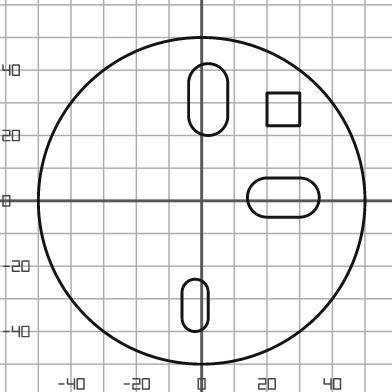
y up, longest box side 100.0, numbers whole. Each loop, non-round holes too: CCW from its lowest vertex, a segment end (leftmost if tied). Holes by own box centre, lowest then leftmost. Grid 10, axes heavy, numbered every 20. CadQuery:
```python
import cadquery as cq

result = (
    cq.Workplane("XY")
    .moveTo(0.0, 0.0)
    .circle(50.0)
    .moveTo(-6.0, -36.0)
    .threePointArc((-2.0, -40.0), (2.0, -36.0))
    .lineTo(2.0, -28.0)
    .threePointArc((-2.0, -24.0), (-6.0, -28.0))
    .close()
    .moveTo(20.0, -5.0)
    .lineTo(30.0, -5.0)
    .threePointArc((36.0, 1.0), (30.0, 7.0))
    .lineTo(20.0, 7.0)
    .threePointArc((14.0, 1.0), (20.0, -5.0))
    .close()
    .moveTo(20.0, 23.0)
    .lineTo(30.0, 23.0)
    .lineTo(30.0, 33.0)
    .lineTo(20.0, 33.0)
    .close()
    .moveTo(-4.0, 26.0)
    .threePointArc((2.0, 20.0), (8.0, 26.0))
    .lineTo(8.0, 36.0)
    .threePointArc((2.0, 42.0), (-4.0, 36.0))
    .close()
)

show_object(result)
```